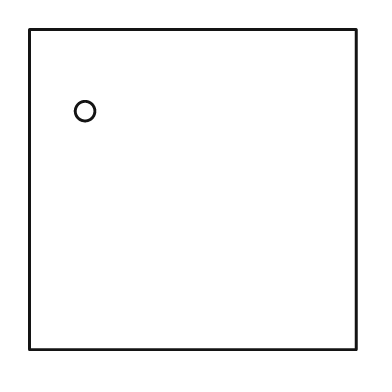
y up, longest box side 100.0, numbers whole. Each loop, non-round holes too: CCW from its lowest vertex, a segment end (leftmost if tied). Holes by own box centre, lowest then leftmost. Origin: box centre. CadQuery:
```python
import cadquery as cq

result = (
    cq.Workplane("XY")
    .moveTo(-50.0, -49.0)
    .lineTo(50.0, -49.0)
    .lineTo(50.0, 49.0)
    .lineTo(-50.0, 49.0)
    .close()
    .moveTo(-33.0, 24.0)
    .circle(3.0)
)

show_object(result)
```